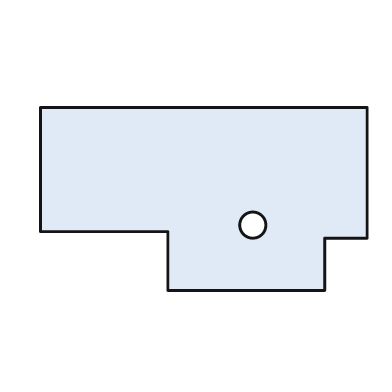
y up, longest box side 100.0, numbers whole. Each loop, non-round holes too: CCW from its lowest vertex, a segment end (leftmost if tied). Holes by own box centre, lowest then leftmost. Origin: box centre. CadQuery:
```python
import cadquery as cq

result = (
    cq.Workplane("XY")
    .moveTo(-11.0, -28.0)
    .lineTo(37.0, -28.0)
    .lineTo(37.0, -12.0)
    .lineTo(50.0, -12.0)
    .lineTo(50.0, 28.0)
    .lineTo(-50.0, 28.0)
    .lineTo(-50.0, -10.0)
    .lineTo(-11.0, -10.0)
    .close()
    .moveTo(15.0, -8.0)
    .circle(4.0)
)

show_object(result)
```